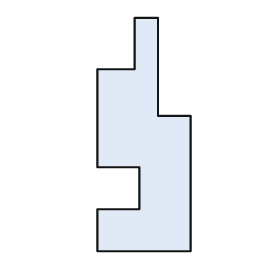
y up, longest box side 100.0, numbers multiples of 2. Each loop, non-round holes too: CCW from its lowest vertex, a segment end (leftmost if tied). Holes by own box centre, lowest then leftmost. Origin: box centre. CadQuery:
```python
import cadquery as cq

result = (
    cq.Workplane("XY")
    .moveTo(-20.0, -50.0)
    .lineTo(20.0, -50.0)
    .lineTo(20.0, 8.0)
    .lineTo(6.0, 8.0)
    .lineTo(6.0, 50.0)
    .lineTo(-4.0, 50.0)
    .lineTo(-4.0, 28.0)
    .lineTo(-20.0, 28.0)
    .lineTo(-20.0, -14.0)
    .lineTo(-2.0, -14.0)
    .lineTo(-2.0, -32.0)
    .lineTo(-20.0, -32.0)
    .close()
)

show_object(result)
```